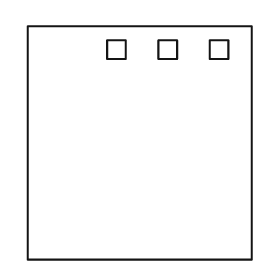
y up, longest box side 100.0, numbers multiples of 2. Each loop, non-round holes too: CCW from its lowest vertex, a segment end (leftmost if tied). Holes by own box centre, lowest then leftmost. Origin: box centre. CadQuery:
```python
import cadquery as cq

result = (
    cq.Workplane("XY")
    .moveTo(-48.0, -50.0)
    .lineTo(48.0, -50.0)
    .lineTo(48.0, 50.0)
    .lineTo(-48.0, 50.0)
    .close()
    .moveTo(-14.0, 36.0)
    .lineTo(-6.0, 36.0)
    .lineTo(-6.0, 44.0)
    .lineTo(-14.0, 44.0)
    .close()
    .moveTo(8.0, 36.0)
    .lineTo(16.0, 36.0)
    .lineTo(16.0, 44.0)
    .lineTo(8.0, 44.0)
    .close()
    .moveTo(30.0, 36.0)
    .lineTo(38.0, 36.0)
    .lineTo(38.0, 44.0)
    .lineTo(30.0, 44.0)
    .close()
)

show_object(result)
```